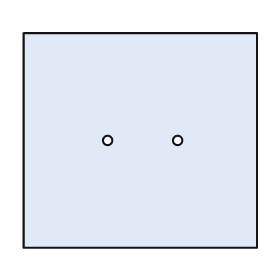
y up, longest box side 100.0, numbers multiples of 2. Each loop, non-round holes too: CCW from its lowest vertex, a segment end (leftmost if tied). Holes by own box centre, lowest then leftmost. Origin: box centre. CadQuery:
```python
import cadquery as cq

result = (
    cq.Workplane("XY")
    .moveTo(-50.0, -46.0)
    .lineTo(50.0, -46.0)
    .lineTo(50.0, 46.0)
    .lineTo(-50.0, 46.0)
    .close()
    .moveTo(-14.0, 0.0)
    .circle(2.0)
    .moveTo(16.0, 0.0)
    .circle(2.0)
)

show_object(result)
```